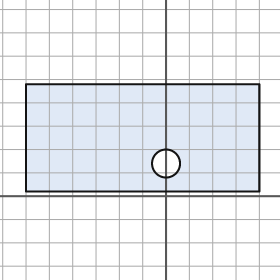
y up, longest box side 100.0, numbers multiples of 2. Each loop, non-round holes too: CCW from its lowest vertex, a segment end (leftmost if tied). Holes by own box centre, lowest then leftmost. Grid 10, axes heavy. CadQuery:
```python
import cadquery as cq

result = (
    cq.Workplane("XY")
    .moveTo(-60.0, 2.0)
    .lineTo(40.0, 2.0)
    .lineTo(40.0, 48.0)
    .lineTo(-60.0, 48.0)
    .close()
    .moveTo(0.0, 14.0)
    .circle(6.0)
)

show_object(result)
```